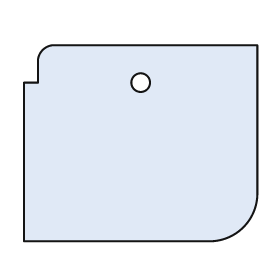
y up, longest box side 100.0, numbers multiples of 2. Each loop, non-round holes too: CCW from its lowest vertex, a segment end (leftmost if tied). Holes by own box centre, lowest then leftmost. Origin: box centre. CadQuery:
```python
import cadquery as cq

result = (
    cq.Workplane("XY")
    .moveTo(-50.0, -42.0)
    .lineTo(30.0, -42.0)
    .threePointArc((44.0, -36.0), (50.0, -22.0))
    .lineTo(50.0, 42.0)
    .lineTo(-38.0, 42.0)
    .threePointArc((-42.0, 40.0), (-44.0, 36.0))
    .lineTo(-44.0, 26.0)
    .lineTo(-50.0, 26.0)
    .close()
    .moveTo(0.0, 26.0)
    .circle(4.0)
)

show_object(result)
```